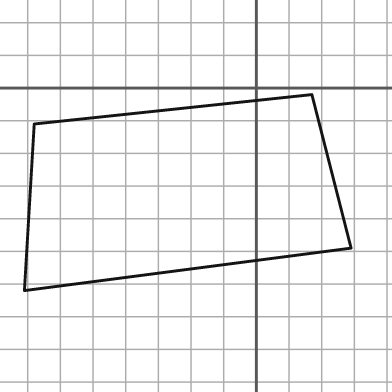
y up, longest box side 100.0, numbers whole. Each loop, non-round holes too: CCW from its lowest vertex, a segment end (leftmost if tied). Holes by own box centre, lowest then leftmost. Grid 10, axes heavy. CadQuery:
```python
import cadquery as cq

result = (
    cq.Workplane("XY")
    .moveTo(-71.0, -62.0)
    .lineTo(29.0, -49.0)
    .lineTo(17.0, -2.0)
    .lineTo(-68.0, -11.0)
    .close()
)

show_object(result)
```